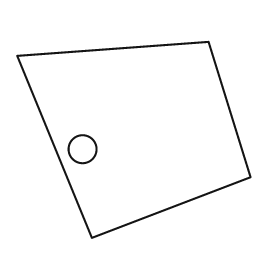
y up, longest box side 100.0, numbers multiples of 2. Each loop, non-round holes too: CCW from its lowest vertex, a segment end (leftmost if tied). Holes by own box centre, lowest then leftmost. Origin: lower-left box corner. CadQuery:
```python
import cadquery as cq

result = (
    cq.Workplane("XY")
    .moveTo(32.0, 0.0)
    .lineTo(100.0, 26.0)
    .lineTo(82.0, 84.0)
    .lineTo(0.0, 78.0)
    .close()
    .moveTo(28.0, 38.0)
    .circle(6.0)
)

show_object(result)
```